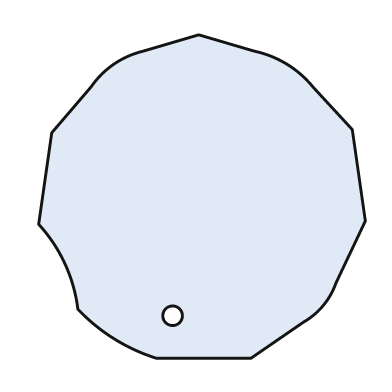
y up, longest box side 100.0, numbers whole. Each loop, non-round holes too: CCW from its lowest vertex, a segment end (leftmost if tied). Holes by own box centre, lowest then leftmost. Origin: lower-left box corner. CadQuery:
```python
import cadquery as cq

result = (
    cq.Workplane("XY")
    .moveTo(36.0, 0.0)
    .lineTo(65.0, 0.0)
    .lineTo(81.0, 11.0)
    .threePointArc((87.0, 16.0), (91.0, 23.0))
    .lineTo(100.0, 42.0)
    .lineTo(96.0, 70.0)
    .lineTo(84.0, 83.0)
    .threePointArc((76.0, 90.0), (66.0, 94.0))
    .lineTo(49.0, 99.0)
    .lineTo(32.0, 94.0)
    .threePointArc((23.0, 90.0), (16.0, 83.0))
    .lineTo(4.0, 69.0)
    .lineTo(0.0, 41.0)
    .threePointArc((8.0, 29.0), (12.0, 15.0))
    .threePointArc((23.0, 6.0), (36.0, 0.0))
    .close()
    .moveTo(41.0, 13.0)
    .circle(3.0)
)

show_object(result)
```